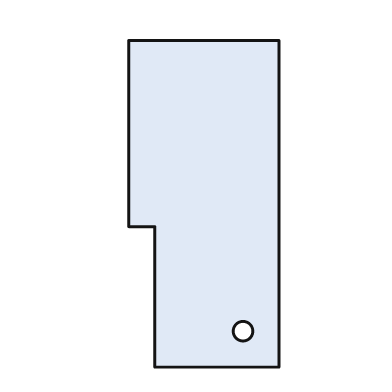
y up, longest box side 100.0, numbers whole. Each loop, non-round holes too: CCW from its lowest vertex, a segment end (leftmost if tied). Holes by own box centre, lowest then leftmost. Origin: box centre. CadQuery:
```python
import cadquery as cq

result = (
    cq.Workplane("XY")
    .moveTo(-15.0, -50.0)
    .lineTo(23.0, -50.0)
    .lineTo(23.0, 50.0)
    .lineTo(-23.0, 50.0)
    .lineTo(-23.0, -7.0)
    .lineTo(-15.0, -7.0)
    .close()
    .moveTo(12.0, -39.0)
    .circle(3.0)
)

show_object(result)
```